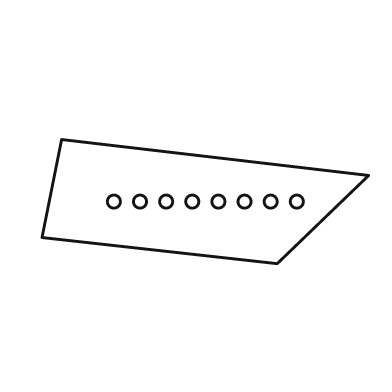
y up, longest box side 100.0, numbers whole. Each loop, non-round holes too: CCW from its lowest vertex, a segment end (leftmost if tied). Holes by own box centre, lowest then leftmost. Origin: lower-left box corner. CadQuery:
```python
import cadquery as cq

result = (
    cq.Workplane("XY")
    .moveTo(72.0, 0.0)
    .lineTo(100.0, 27.0)
    .lineTo(6.0, 38.0)
    .lineTo(0.0, 8.0)
    .close()
    .moveTo(22.0, 19.0)
    .circle(2.0)
    .moveTo(30.0, 19.0)
    .circle(2.0)
    .moveTo(38.0, 19.0)
    .circle(2.0)
    .moveTo(46.0, 19.0)
    .circle(2.0)
    .moveTo(54.0, 19.0)
    .circle(2.0)
    .moveTo(62.0, 19.0)
    .circle(2.0)
    .moveTo(70.0, 19.0)
    .circle(2.0)
    .moveTo(78.0, 19.0)
    .circle(2.0)
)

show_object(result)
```